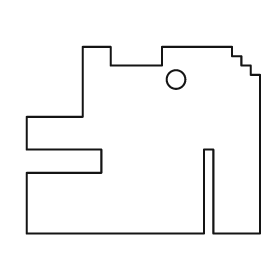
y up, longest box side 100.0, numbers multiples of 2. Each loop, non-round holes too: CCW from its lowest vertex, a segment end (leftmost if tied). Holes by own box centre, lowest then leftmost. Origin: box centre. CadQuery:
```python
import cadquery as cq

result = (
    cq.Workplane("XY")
    .moveTo(-50.0, -40.0)
    .lineTo(26.0, -40.0)
    .lineTo(26.0, -4.0)
    .lineTo(30.0, -4.0)
    .lineTo(30.0, -40.0)
    .lineTo(50.0, -40.0)
    .lineTo(50.0, 28.0)
    .lineTo(46.0, 28.0)
    .lineTo(46.0, 32.0)
    .lineTo(42.0, 32.0)
    .lineTo(42.0, 36.0)
    .lineTo(38.0, 36.0)
    .lineTo(38.0, 40.0)
    .lineTo(8.0, 40.0)
    .lineTo(8.0, 32.0)
    .lineTo(-14.0, 32.0)
    .lineTo(-14.0, 40.0)
    .lineTo(-26.0, 40.0)
    .lineTo(-26.0, 10.0)
    .lineTo(-50.0, 10.0)
    .lineTo(-50.0, -4.0)
    .lineTo(-18.0, -4.0)
    .lineTo(-18.0, -14.0)
    .lineTo(-50.0, -14.0)
    .close()
    .moveTo(14.0, 26.0)
    .circle(4.0)
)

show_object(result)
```